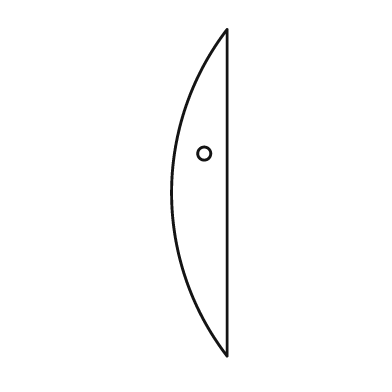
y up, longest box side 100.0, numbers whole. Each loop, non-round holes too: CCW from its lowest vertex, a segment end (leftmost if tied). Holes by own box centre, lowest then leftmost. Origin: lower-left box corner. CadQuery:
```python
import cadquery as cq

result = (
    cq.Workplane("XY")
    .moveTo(17.0, 0.0)
    .lineTo(17.0, 100.0)
    .threePointArc((0.0, 50.0), (17.0, 0.0))
    .close()
    .moveTo(10.0, 62.0)
    .circle(2.0)
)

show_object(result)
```